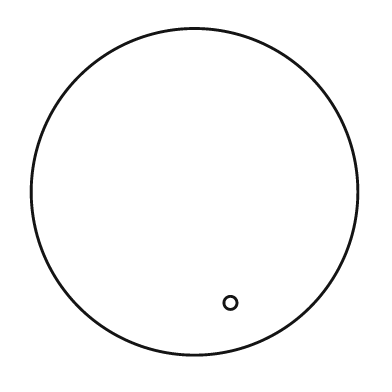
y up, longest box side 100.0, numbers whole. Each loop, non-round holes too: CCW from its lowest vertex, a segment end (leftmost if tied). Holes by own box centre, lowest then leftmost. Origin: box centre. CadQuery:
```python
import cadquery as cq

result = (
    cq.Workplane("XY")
    .moveTo(0.0, 0.0)
    .circle(50.0)
    .moveTo(11.0, -34.0)
    .circle(2.0)
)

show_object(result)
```